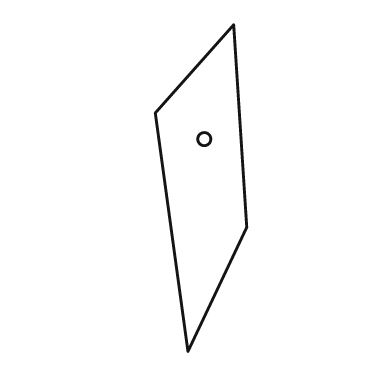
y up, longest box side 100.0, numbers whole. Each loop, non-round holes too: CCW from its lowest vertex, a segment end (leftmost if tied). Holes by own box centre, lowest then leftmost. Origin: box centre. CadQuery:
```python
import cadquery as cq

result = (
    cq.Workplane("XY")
    .moveTo(-4.0, -50.0)
    .lineTo(14.0, -12.0)
    .lineTo(10.0, 50.0)
    .lineTo(-14.0, 23.0)
    .close()
    .moveTo(1.0, 15.0)
    .circle(2.0)
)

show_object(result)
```